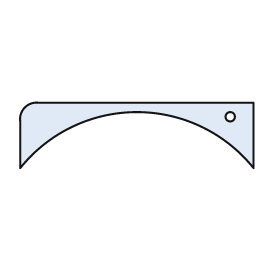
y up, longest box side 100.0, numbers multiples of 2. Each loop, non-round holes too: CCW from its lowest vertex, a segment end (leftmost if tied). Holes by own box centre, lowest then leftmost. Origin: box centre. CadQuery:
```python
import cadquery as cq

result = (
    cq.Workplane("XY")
    .moveTo(-50.0, -14.0)
    .threePointArc((0.0, 10.0), (50.0, -14.0))
    .lineTo(50.0, 14.0)
    .lineTo(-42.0, 14.0)
    .threePointArc((-48.0, 12.0), (-50.0, 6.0))
    .close()
    .moveTo(40.0, 8.0)
    .circle(2.0)
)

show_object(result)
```